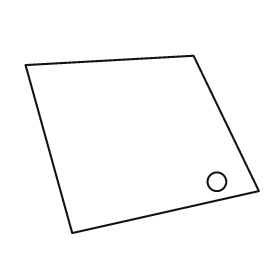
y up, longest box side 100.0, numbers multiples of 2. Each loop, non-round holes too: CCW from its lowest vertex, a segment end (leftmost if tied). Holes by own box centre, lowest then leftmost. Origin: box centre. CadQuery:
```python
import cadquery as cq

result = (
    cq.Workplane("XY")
    .moveTo(-30.0, -38.0)
    .lineTo(50.0, -20.0)
    .lineTo(22.0, 38.0)
    .lineTo(-50.0, 34.0)
    .close()
    .moveTo(32.0, -16.0)
    .circle(4.0)
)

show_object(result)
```